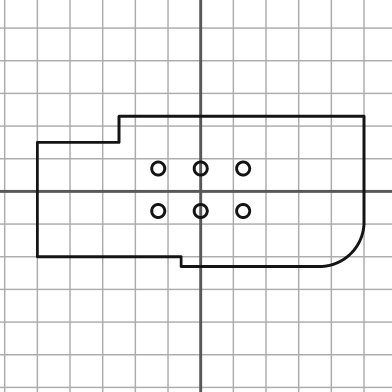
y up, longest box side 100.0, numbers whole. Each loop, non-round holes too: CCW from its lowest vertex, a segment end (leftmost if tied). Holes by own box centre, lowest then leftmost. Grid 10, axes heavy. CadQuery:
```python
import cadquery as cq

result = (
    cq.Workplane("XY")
    .moveTo(-6.0, -23.0)
    .lineTo(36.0, -23.0)
    .threePointArc((46.0, -19.0), (50.0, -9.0))
    .lineTo(50.0, 23.0)
    .lineTo(-25.0, 23.0)
    .lineTo(-25.0, 15.0)
    .lineTo(-50.0, 15.0)
    .lineTo(-50.0, -20.0)
    .lineTo(-6.0, -20.0)
    .close()
    .moveTo(-13.0, -6.0)
    .circle(2.0)
    .moveTo(0.0, -6.0)
    .circle(2.0)
    .moveTo(13.0, -6.0)
    .circle(2.0)
    .moveTo(-13.0, 7.0)
    .circle(2.0)
    .moveTo(0.0, 7.0)
    .circle(2.0)
    .moveTo(13.0, 7.0)
    .circle(2.0)
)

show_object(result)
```